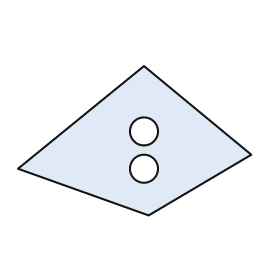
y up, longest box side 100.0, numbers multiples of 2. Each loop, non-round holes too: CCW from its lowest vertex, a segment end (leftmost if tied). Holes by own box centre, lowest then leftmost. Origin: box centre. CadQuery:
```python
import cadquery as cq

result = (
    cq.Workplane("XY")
    .moveTo(6.0, -32.0)
    .lineTo(50.0, -6.0)
    .lineTo(4.0, 32.0)
    .lineTo(-50.0, -12.0)
    .close()
    .moveTo(4.0, -12.0)
    .circle(6.0)
    .moveTo(4.0, 4.0)
    .circle(6.0)
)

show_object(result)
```